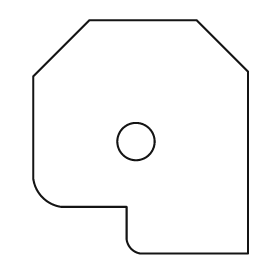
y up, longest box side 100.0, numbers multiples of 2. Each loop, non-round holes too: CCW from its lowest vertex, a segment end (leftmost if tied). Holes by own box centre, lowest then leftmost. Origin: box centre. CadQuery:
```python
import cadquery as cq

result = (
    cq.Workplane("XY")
    .moveTo(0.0, -50.0)
    .lineTo(46.0, -50.0)
    .lineTo(46.0, 28.0)
    .lineTo(24.0, 50.0)
    .lineTo(-22.0, 50.0)
    .lineTo(-46.0, 26.0)
    .lineTo(-46.0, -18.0)
    .threePointArc((-42.0, -26.0), (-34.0, -30.0))
    .lineTo(-6.0, -30.0)
    .lineTo(-6.0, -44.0)
    .threePointArc((-4.0, -48.0), (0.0, -50.0))
    .close()
    .moveTo(-2.0, -2.0)
    .circle(8.0)
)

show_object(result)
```